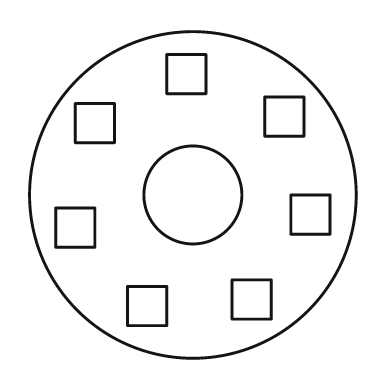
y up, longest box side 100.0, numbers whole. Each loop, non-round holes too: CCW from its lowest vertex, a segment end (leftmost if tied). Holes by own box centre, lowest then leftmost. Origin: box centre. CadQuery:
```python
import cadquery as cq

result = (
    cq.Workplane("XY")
    .moveTo(0.0, 0.0)
    .circle(50.0)
    .moveTo(-20.0, -40.0)
    .lineTo(-8.0, -40.0)
    .lineTo(-8.0, -28.0)
    .lineTo(-20.0, -28.0)
    .close()
    .moveTo(12.0, -38.0)
    .lineTo(24.0, -38.0)
    .lineTo(24.0, -26.0)
    .lineTo(12.0, -26.0)
    .close()
    .moveTo(-42.0, -16.0)
    .lineTo(-30.0, -16.0)
    .lineTo(-30.0, -4.0)
    .lineTo(-42.0, -4.0)
    .close()
    .moveTo(30.0, -12.0)
    .lineTo(42.0, -12.0)
    .lineTo(42.0, 0.0)
    .lineTo(30.0, 0.0)
    .close()
    .moveTo(0.0, 0.0)
    .circle(15.0)
    .moveTo(-36.0, 16.0)
    .lineTo(-24.0, 16.0)
    .lineTo(-24.0, 28.0)
    .lineTo(-36.0, 28.0)
    .close()
    .moveTo(22.0, 18.0)
    .lineTo(34.0, 18.0)
    .lineTo(34.0, 30.0)
    .lineTo(22.0, 30.0)
    .close()
    .moveTo(-8.0, 31.0)
    .lineTo(4.0, 31.0)
    .lineTo(4.0, 43.0)
    .lineTo(-8.0, 43.0)
    .close()
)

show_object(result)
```